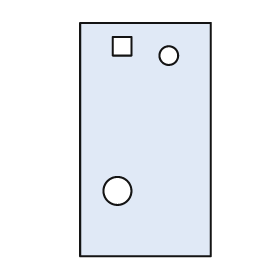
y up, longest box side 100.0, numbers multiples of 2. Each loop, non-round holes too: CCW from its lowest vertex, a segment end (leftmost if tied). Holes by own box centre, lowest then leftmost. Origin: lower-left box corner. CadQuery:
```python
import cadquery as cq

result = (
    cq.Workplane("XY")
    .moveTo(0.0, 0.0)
    .lineTo(56.0, 0.0)
    .lineTo(56.0, 100.0)
    .lineTo(0.0, 100.0)
    .close()
    .moveTo(16.0, 28.0)
    .circle(6.0)
    .moveTo(38.0, 86.0)
    .circle(4.0)
    .moveTo(14.0, 86.0)
    .lineTo(22.0, 86.0)
    .lineTo(22.0, 94.0)
    .lineTo(14.0, 94.0)
    .close()
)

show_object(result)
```